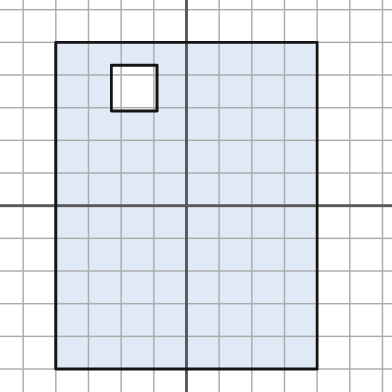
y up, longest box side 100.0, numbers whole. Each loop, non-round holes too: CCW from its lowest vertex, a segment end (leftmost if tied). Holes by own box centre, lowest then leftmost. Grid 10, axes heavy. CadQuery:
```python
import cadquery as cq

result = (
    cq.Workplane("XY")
    .moveTo(-40.0, -50.0)
    .lineTo(40.0, -50.0)
    .lineTo(40.0, 50.0)
    .lineTo(-40.0, 50.0)
    .close()
    .moveTo(-23.0, 29.0)
    .lineTo(-9.0, 29.0)
    .lineTo(-9.0, 43.0)
    .lineTo(-23.0, 43.0)
    .close()
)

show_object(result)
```